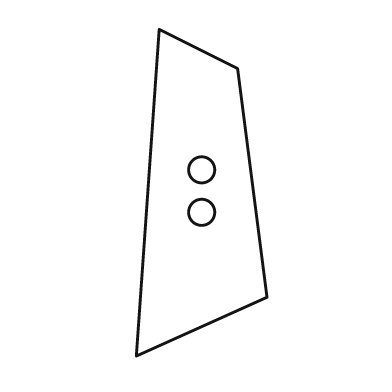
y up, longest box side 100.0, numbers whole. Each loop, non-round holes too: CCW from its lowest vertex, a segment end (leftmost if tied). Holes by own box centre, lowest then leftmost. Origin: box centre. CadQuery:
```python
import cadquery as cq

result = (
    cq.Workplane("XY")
    .moveTo(-20.0, -50.0)
    .lineTo(20.0, -32.0)
    .lineTo(11.0, 38.0)
    .lineTo(-13.0, 50.0)
    .close()
    .moveTo(0.0, -6.0)
    .circle(4.0)
    .moveTo(0.0, 7.0)
    .circle(4.0)
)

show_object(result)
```